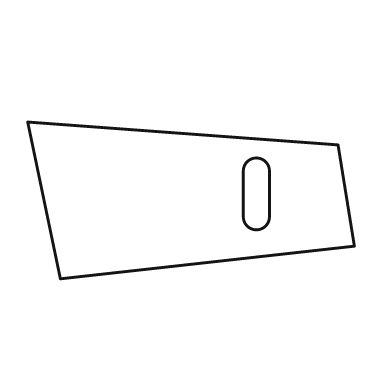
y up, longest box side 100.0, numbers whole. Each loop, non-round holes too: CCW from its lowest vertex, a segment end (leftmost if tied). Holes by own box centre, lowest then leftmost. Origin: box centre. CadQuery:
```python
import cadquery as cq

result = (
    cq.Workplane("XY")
    .moveTo(-40.0, -24.0)
    .lineTo(50.0, -14.0)
    .lineTo(45.0, 17.0)
    .lineTo(-50.0, 24.0)
    .close()
    .moveTo(16.0, -5.0)
    .threePointArc((20.0, -9.0), (24.0, -5.0))
    .lineTo(24.0, 9.0)
    .threePointArc((20.0, 13.0), (16.0, 9.0))
    .close()
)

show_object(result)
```